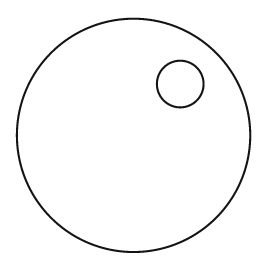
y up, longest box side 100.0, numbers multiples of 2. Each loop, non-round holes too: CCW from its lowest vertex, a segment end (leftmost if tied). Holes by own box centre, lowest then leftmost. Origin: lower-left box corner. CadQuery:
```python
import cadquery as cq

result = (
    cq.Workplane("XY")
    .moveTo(50.0, 50.0)
    .circle(50.0)
    .moveTo(70.0, 72.0)
    .circle(10.0)
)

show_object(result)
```